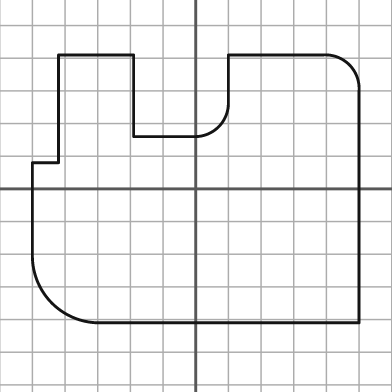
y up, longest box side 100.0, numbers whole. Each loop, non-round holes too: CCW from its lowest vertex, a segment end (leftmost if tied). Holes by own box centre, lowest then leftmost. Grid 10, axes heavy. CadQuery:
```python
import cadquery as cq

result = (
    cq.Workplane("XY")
    .moveTo(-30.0, -41.0)
    .lineTo(50.0, -41.0)
    .lineTo(50.0, 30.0)
    .threePointArc((47.0, 38.0), (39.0, 41.0))
    .lineTo(10.0, 41.0)
    .lineTo(10.0, 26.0)
    .threePointArc((7.0, 19.0), (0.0, 16.0))
    .lineTo(-19.0, 16.0)
    .lineTo(-19.0, 41.0)
    .lineTo(-42.0, 41.0)
    .lineTo(-42.0, 8.0)
    .lineTo(-50.0, 8.0)
    .lineTo(-50.0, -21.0)
    .threePointArc((-44.0, -35.0), (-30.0, -41.0))
    .close()
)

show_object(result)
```